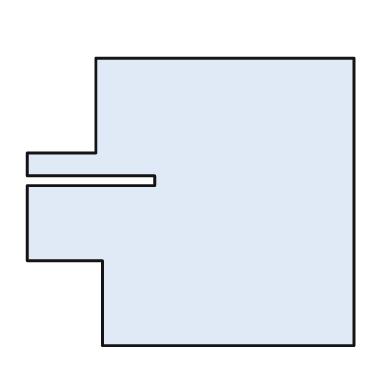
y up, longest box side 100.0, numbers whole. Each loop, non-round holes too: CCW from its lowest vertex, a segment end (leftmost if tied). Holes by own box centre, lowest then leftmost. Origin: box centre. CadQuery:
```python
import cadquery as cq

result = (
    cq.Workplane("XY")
    .moveTo(-27.0, -44.0)
    .lineTo(50.0, -44.0)
    .lineTo(50.0, 44.0)
    .lineTo(-29.0, 44.0)
    .lineTo(-29.0, 15.0)
    .lineTo(-50.0, 15.0)
    .lineTo(-50.0, 8.0)
    .lineTo(-11.0, 8.0)
    .lineTo(-11.0, 5.0)
    .lineTo(-50.0, 5.0)
    .lineTo(-50.0, -18.0)
    .lineTo(-27.0, -18.0)
    .close()
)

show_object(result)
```